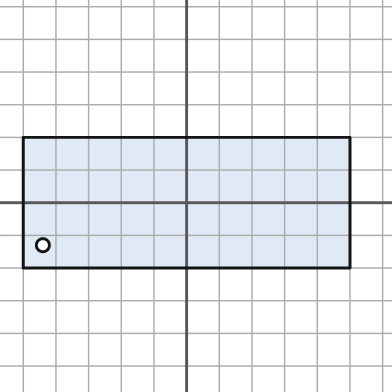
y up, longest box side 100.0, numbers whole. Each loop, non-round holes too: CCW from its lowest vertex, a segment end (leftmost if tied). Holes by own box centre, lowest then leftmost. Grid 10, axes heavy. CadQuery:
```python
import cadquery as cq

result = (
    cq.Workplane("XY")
    .moveTo(-50.0, -20.0)
    .lineTo(50.0, -20.0)
    .lineTo(50.0, 20.0)
    .lineTo(-50.0, 20.0)
    .close()
    .moveTo(-44.0, -13.0)
    .circle(2.0)
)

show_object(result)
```